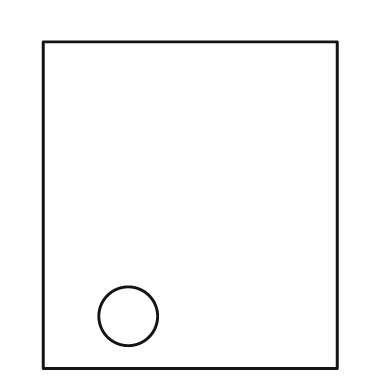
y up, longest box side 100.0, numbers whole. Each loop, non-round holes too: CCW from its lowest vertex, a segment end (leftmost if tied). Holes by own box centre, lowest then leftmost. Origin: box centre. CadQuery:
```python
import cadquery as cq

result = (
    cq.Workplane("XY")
    .moveTo(-45.0, -50.0)
    .lineTo(45.0, -50.0)
    .lineTo(45.0, 50.0)
    .lineTo(-45.0, 50.0)
    .close()
    .moveTo(-19.0, -34.0)
    .circle(9.0)
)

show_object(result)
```